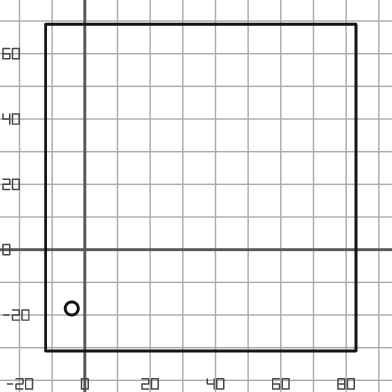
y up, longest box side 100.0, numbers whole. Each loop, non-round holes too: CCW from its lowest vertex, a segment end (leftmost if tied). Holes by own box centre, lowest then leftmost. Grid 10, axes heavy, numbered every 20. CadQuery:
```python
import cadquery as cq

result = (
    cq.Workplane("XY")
    .moveTo(-12.0, -31.0)
    .lineTo(83.0, -31.0)
    .lineTo(83.0, 69.0)
    .lineTo(-12.0, 69.0)
    .close()
    .moveTo(-4.0, -18.0)
    .circle(2.0)
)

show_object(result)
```